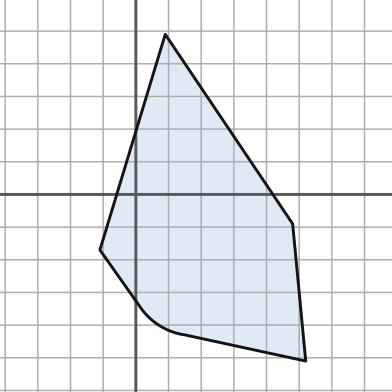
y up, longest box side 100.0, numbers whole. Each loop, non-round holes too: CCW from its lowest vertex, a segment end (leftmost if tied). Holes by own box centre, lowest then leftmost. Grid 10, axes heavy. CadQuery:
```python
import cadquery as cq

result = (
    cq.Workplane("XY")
    .moveTo(52.0, -51.0)
    .lineTo(48.0, -9.0)
    .lineTo(9.0, 49.0)
    .lineTo(-11.0, -17.0)
    .lineTo(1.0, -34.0)
    .threePointArc((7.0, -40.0), (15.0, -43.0))
    .close()
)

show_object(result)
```